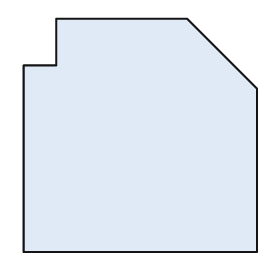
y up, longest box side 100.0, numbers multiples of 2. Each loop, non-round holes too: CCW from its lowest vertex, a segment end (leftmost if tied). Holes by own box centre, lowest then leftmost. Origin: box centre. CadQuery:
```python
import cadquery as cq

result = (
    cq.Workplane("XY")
    .moveTo(-50.0, -50.0)
    .lineTo(50.0, -50.0)
    .lineTo(50.0, 20.0)
    .lineTo(20.0, 50.0)
    .lineTo(-36.0, 50.0)
    .lineTo(-36.0, 30.0)
    .lineTo(-50.0, 30.0)
    .close()
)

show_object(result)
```